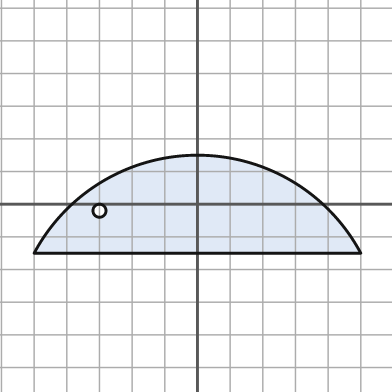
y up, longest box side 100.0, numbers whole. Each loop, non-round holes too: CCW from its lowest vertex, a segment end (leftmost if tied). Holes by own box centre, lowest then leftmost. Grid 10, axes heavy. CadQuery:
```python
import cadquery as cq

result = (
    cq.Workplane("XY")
    .moveTo(-50.0, -15.0)
    .lineTo(50.0, -15.0)
    .threePointArc((0.0, 15.0), (-50.0, -15.0))
    .close()
    .moveTo(-30.0, -2.0)
    .circle(2.0)
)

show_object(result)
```